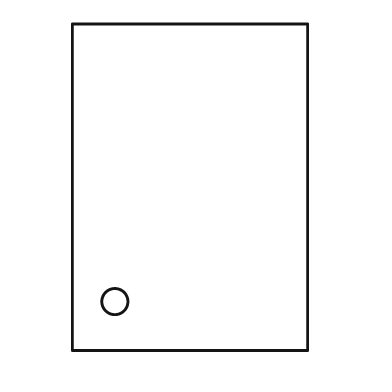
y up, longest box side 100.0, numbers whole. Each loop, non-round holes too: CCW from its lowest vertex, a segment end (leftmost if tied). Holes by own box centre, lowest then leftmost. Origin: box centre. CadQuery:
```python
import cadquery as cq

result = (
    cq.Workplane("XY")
    .moveTo(-36.0, -50.0)
    .lineTo(36.0, -50.0)
    .lineTo(36.0, 50.0)
    .lineTo(-36.0, 50.0)
    .close()
    .moveTo(-23.0, -35.0)
    .circle(4.0)
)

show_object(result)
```